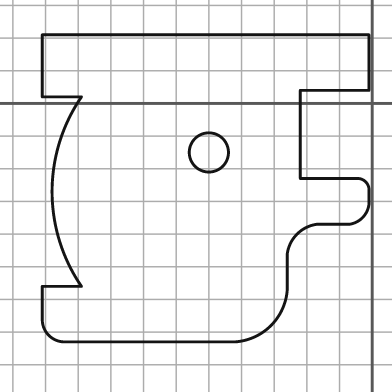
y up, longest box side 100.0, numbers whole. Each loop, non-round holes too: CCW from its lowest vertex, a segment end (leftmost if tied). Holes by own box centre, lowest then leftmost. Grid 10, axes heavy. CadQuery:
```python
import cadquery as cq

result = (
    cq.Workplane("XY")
    .moveTo(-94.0, -73.0)
    .lineTo(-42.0, -73.0)
    .threePointArc((-31.0, -68.0), (-26.0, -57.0))
    .lineTo(-26.0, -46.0)
    .threePointArc((-23.0, -40.0), (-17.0, -37.0))
    .lineTo(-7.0, -37.0)
    .threePointArc((-3.0, -35.0), (-1.0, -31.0))
    .lineTo(-1.0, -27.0)
    .threePointArc((-2.0, -24.0), (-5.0, -23.0))
    .lineTo(-22.0, -23.0)
    .lineTo(-22.0, 4.0)
    .lineTo(-1.0, 4.0)
    .lineTo(-1.0, 21.0)
    .lineTo(-101.0, 21.0)
    .lineTo(-101.0, 2.0)
    .lineTo(-89.0, 2.0)
    .threePointArc((-98.0, -27.0), (-89.0, -56.0))
    .lineTo(-101.0, -56.0)
    .lineTo(-101.0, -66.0)
    .threePointArc((-99.0, -71.0), (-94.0, -73.0))
    .close()
    .moveTo(-50.0, -15.0)
    .circle(6.0)
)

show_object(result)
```